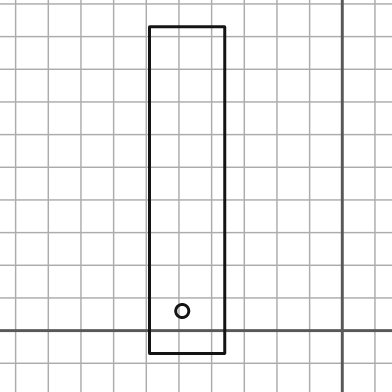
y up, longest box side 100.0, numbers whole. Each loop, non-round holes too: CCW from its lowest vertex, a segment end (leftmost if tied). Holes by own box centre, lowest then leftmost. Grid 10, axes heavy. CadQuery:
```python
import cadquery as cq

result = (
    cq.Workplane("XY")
    .moveTo(-59.0, -7.0)
    .lineTo(-36.0, -7.0)
    .lineTo(-36.0, 93.0)
    .lineTo(-59.0, 93.0)
    .close()
    .moveTo(-49.0, 6.0)
    .circle(2.0)
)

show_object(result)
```